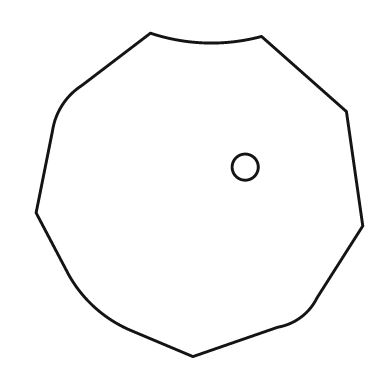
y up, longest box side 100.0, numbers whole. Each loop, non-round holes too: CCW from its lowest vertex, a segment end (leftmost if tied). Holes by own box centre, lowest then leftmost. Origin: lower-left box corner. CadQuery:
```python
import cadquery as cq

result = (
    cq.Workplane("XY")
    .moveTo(48.0, 0.0)
    .lineTo(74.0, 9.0)
    .threePointArc((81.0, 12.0), (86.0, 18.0))
    .lineTo(100.0, 40.0)
    .lineTo(95.0, 75.0)
    .lineTo(69.0, 98.0)
    .threePointArc((52.0, 96.0), (35.0, 99.0))
    .lineTo(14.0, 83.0)
    .threePointArc((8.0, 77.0), (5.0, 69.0))
    .lineTo(0.0, 44.0)
    .lineTo(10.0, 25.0)
    .threePointArc((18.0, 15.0), (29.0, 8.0))
    .close()
    .moveTo(64.0, 58.0)
    .circle(4.0)
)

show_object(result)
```